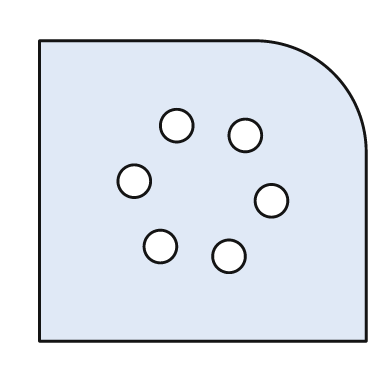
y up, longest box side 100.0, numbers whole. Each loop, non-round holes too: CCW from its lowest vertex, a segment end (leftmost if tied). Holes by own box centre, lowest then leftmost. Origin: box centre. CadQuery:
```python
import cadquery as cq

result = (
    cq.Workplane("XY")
    .moveTo(-50.0, -46.0)
    .lineTo(50.0, -46.0)
    .lineTo(50.0, 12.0)
    .threePointArc((40.0, 36.0), (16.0, 46.0))
    .lineTo(-50.0, 46.0)
    .close()
    .moveTo(8.0, -20.0)
    .circle(5.0)
    .moveTo(-13.0, -17.0)
    .circle(5.0)
    .moveTo(21.0, -3.0)
    .circle(5.0)
    .moveTo(-21.0, 3.0)
    .circle(5.0)
    .moveTo(13.0, 17.0)
    .circle(5.0)
    .moveTo(-8.0, 20.0)
    .circle(5.0)
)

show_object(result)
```